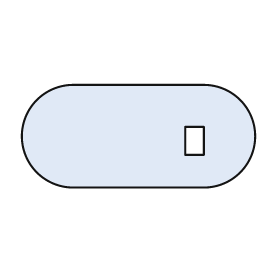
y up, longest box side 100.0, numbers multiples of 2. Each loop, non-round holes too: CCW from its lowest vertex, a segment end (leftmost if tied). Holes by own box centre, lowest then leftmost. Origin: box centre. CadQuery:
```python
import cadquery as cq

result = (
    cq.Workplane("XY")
    .moveTo(-28.0, -22.0)
    .lineTo(28.0, -22.0)
    .threePointArc((50.0, 0.0), (28.0, 22.0))
    .lineTo(-28.0, 22.0)
    .threePointArc((-50.0, 0.0), (-28.0, -22.0))
    .close()
    .moveTo(20.0, -8.0)
    .lineTo(28.0, -8.0)
    .lineTo(28.0, 4.0)
    .lineTo(20.0, 4.0)
    .close()
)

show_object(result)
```